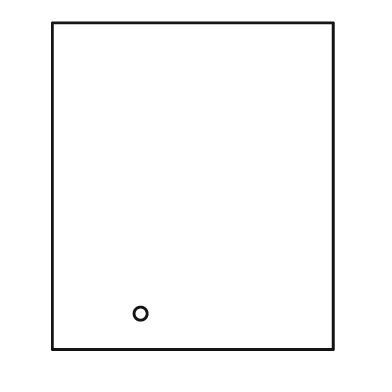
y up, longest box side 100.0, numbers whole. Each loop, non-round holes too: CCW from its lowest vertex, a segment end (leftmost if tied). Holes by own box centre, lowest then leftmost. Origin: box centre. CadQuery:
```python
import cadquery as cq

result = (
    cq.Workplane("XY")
    .moveTo(-43.0, -50.0)
    .lineTo(43.0, -50.0)
    .lineTo(43.0, 50.0)
    .lineTo(-43.0, 50.0)
    .close()
    .moveTo(-16.0, -39.0)
    .circle(2.0)
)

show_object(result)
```